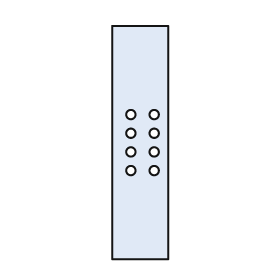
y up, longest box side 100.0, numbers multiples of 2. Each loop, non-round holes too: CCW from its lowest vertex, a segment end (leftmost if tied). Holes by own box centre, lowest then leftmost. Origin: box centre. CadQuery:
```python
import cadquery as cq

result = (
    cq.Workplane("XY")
    .moveTo(-12.0, -50.0)
    .lineTo(12.0, -50.0)
    .lineTo(12.0, 50.0)
    .lineTo(-12.0, 50.0)
    .close()
    .moveTo(-4.0, -12.0)
    .circle(2.0)
    .moveTo(6.0, -12.0)
    .circle(2.0)
    .moveTo(-4.0, -4.0)
    .circle(2.0)
    .moveTo(6.0, -4.0)
    .circle(2.0)
    .moveTo(-4.0, 4.0)
    .circle(2.0)
    .moveTo(6.0, 4.0)
    .circle(2.0)
    .moveTo(-4.0, 12.0)
    .circle(2.0)
    .moveTo(6.0, 12.0)
    .circle(2.0)
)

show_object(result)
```